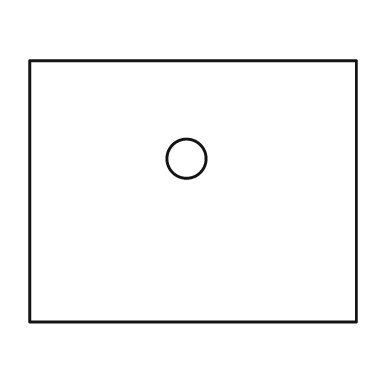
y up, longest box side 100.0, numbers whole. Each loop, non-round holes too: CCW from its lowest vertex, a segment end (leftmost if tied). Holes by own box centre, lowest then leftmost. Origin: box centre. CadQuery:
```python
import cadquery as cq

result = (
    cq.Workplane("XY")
    .moveTo(-50.0, -40.0)
    .lineTo(50.0, -40.0)
    .lineTo(50.0, 40.0)
    .lineTo(-50.0, 40.0)
    .close()
    .moveTo(-2.0, 10.0)
    .circle(6.0)
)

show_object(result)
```